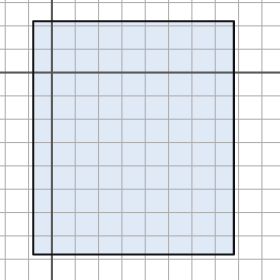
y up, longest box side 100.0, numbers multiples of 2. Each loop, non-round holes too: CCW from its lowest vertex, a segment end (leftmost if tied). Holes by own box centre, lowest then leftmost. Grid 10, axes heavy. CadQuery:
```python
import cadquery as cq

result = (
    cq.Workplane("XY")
    .moveTo(-8.0, -78.0)
    .lineTo(78.0, -78.0)
    .lineTo(78.0, 22.0)
    .lineTo(-8.0, 22.0)
    .close()
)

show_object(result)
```